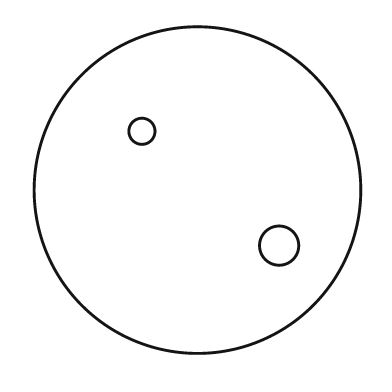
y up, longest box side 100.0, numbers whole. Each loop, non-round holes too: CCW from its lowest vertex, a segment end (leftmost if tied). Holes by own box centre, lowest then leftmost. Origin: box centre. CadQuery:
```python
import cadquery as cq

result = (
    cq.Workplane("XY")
    .moveTo(0.0, 0.0)
    .circle(50.0)
    .moveTo(25.0, -17.0)
    .circle(6.0)
    .moveTo(-17.0, 18.0)
    .circle(4.0)
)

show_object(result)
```